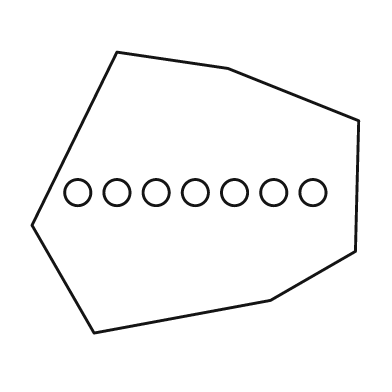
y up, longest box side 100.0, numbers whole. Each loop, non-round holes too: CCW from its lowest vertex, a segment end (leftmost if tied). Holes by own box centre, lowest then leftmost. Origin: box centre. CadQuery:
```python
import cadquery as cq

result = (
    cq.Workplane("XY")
    .moveTo(-31.0, -43.0)
    .lineTo(23.0, -33.0)
    .lineTo(49.0, -18.0)
    .lineTo(50.0, 22.0)
    .lineTo(10.0, 38.0)
    .lineTo(-24.0, 43.0)
    .lineTo(-50.0, -10.0)
    .close()
    .moveTo(-36.0, 0.0)
    .circle(4.0)
    .moveTo(-24.0, 0.0)
    .circle(4.0)
    .moveTo(-12.0, 0.0)
    .circle(4.0)
    .moveTo(0.0, 0.0)
    .circle(4.0)
    .moveTo(12.0, 0.0)
    .circle(4.0)
    .moveTo(24.0, 0.0)
    .circle(4.0)
    .moveTo(36.0, 0.0)
    .circle(4.0)
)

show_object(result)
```